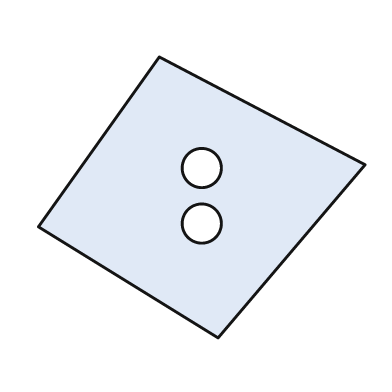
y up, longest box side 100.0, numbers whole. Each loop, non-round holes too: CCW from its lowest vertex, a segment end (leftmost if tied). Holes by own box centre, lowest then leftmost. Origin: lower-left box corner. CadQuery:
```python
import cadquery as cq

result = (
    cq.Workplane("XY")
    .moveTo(55.0, 0.0)
    .lineTo(100.0, 53.0)
    .lineTo(37.0, 86.0)
    .lineTo(0.0, 34.0)
    .close()
    .moveTo(50.0, 35.0)
    .circle(6.0)
    .moveTo(50.0, 52.0)
    .circle(6.0)
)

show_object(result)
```